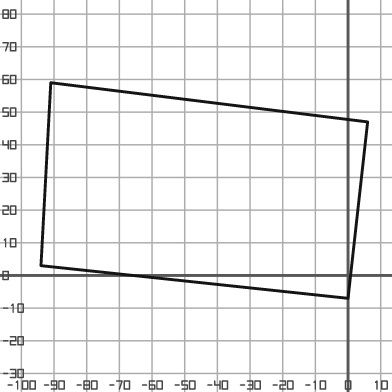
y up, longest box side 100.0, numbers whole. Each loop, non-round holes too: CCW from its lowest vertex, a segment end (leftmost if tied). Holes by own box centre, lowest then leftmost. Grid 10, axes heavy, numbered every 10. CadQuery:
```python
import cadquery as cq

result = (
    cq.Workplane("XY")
    .moveTo(0.0, -7.0)
    .lineTo(6.0, 47.0)
    .lineTo(-91.0, 59.0)
    .lineTo(-94.0, 3.0)
    .close()
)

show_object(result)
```